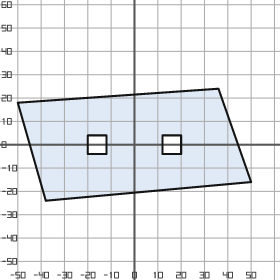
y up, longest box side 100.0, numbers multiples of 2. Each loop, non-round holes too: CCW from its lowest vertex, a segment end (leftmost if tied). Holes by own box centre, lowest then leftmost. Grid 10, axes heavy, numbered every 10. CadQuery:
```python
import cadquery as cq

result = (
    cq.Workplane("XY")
    .moveTo(-38.0, -24.0)
    .lineTo(50.0, -16.0)
    .lineTo(36.0, 24.0)
    .lineTo(-50.0, 18.0)
    .close()
    .moveTo(-20.0, -4.0)
    .lineTo(-12.0, -4.0)
    .lineTo(-12.0, 4.0)
    .lineTo(-20.0, 4.0)
    .close()
    .moveTo(12.0, -4.0)
    .lineTo(20.0, -4.0)
    .lineTo(20.0, 4.0)
    .lineTo(12.0, 4.0)
    .close()
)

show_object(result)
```